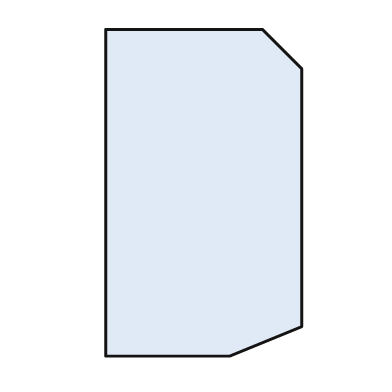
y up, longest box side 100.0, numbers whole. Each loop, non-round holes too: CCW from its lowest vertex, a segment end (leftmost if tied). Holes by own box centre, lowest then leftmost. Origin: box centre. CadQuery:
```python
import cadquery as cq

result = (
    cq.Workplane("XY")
    .moveTo(-30.0, -50.0)
    .lineTo(8.0, -50.0)
    .lineTo(30.0, -41.0)
    .lineTo(30.0, 38.0)
    .lineTo(18.0, 50.0)
    .lineTo(-30.0, 50.0)
    .close()
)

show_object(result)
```